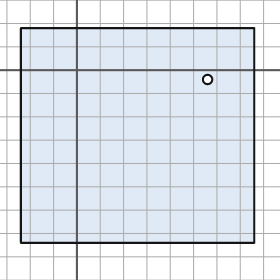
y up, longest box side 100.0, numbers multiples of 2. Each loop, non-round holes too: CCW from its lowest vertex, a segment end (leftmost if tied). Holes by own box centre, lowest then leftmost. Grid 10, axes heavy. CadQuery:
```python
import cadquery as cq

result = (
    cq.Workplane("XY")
    .moveTo(-24.0, -74.0)
    .lineTo(76.0, -74.0)
    .lineTo(76.0, 18.0)
    .lineTo(-24.0, 18.0)
    .close()
    .moveTo(56.0, -4.0)
    .circle(2.0)
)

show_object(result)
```